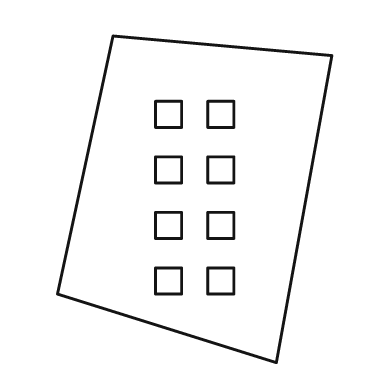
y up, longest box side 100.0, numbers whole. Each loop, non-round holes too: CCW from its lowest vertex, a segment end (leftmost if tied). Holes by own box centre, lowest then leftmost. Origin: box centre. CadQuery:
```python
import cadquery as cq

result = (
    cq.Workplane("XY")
    .moveTo(25.0, -50.0)
    .lineTo(42.0, 44.0)
    .lineTo(-25.0, 50.0)
    .lineTo(-42.0, -29.0)
    .close()
    .moveTo(-12.0, -29.0)
    .lineTo(-4.0, -29.0)
    .lineTo(-4.0, -21.0)
    .lineTo(-12.0, -21.0)
    .close()
    .moveTo(4.0, -29.0)
    .lineTo(12.0, -29.0)
    .lineTo(12.0, -21.0)
    .lineTo(4.0, -21.0)
    .close()
    .moveTo(-12.0, -12.0)
    .lineTo(-4.0, -12.0)
    .lineTo(-4.0, -4.0)
    .lineTo(-12.0, -4.0)
    .close()
    .moveTo(4.0, -12.0)
    .lineTo(12.0, -12.0)
    .lineTo(12.0, -4.0)
    .lineTo(4.0, -4.0)
    .close()
    .moveTo(-12.0, 5.0)
    .lineTo(-4.0, 5.0)
    .lineTo(-4.0, 13.0)
    .lineTo(-12.0, 13.0)
    .close()
    .moveTo(4.0, 5.0)
    .lineTo(12.0, 5.0)
    .lineTo(12.0, 13.0)
    .lineTo(4.0, 13.0)
    .close()
    .moveTo(-12.0, 22.0)
    .lineTo(-4.0, 22.0)
    .lineTo(-4.0, 30.0)
    .lineTo(-12.0, 30.0)
    .close()
    .moveTo(4.0, 22.0)
    .lineTo(12.0, 22.0)
    .lineTo(12.0, 30.0)
    .lineTo(4.0, 30.0)
    .close()
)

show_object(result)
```